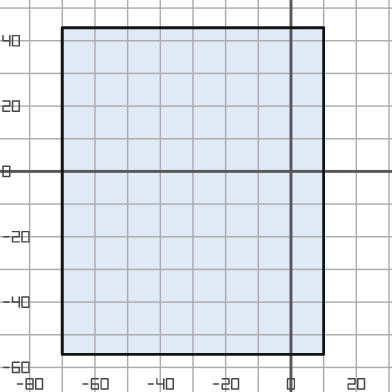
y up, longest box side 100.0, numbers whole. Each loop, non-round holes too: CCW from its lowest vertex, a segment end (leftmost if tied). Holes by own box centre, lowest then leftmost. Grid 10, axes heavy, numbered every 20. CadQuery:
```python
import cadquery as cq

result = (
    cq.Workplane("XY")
    .moveTo(-70.0, -56.0)
    .lineTo(10.0, -56.0)
    .lineTo(10.0, 44.0)
    .lineTo(-70.0, 44.0)
    .close()
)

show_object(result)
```